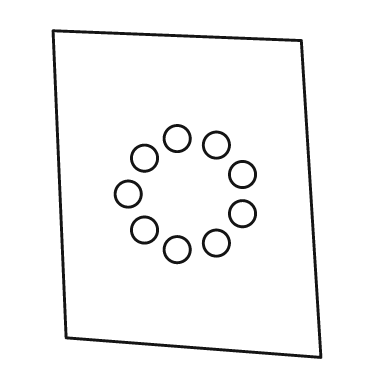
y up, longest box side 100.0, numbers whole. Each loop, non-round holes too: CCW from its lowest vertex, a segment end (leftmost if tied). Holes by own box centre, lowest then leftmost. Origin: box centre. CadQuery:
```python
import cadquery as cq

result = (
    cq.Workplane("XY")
    .moveTo(41.0, -50.0)
    .lineTo(35.0, 47.0)
    .lineTo(-41.0, 50.0)
    .lineTo(-37.0, -44.0)
    .close()
    .moveTo(-3.0, -17.0)
    .circle(4.0)
    .moveTo(9.0, -15.0)
    .circle(4.0)
    .moveTo(-13.0, -11.0)
    .circle(4.0)
    .moveTo(17.0, -6.0)
    .circle(4.0)
    .moveTo(-18.0, 0.0)
    .circle(4.0)
    .moveTo(17.0, 6.0)
    .circle(4.0)
    .moveTo(-13.0, 11.0)
    .circle(4.0)
    .moveTo(9.0, 15.0)
    .circle(4.0)
    .moveTo(-3.0, 17.0)
    .circle(4.0)
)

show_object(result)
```